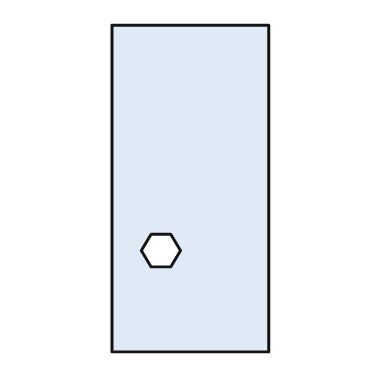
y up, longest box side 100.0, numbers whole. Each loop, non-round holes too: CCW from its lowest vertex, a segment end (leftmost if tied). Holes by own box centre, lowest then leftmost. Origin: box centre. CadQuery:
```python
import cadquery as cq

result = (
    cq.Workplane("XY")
    .moveTo(-24.0, -50.0)
    .lineTo(24.0, -50.0)
    .lineTo(24.0, 50.0)
    .lineTo(-24.0, 50.0)
    .close()
    .moveTo(-12.0, -24.0)
    .lineTo(-6.0, -24.0)
    .lineTo(-3.0, -19.0)
    .lineTo(-6.0, -14.0)
    .lineTo(-12.0, -14.0)
    .lineTo(-15.0, -19.0)
    .close()
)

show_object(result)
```